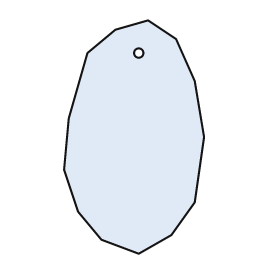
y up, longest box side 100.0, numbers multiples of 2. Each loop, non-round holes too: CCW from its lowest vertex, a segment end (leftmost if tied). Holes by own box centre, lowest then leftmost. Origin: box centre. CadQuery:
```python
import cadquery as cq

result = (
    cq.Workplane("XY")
    .moveTo(2.0, -50.0)
    .lineTo(16.0, -42.0)
    .lineTo(26.0, -28.0)
    .lineTo(30.0, 0.0)
    .lineTo(26.0, 24.0)
    .lineTo(18.0, 42.0)
    .lineTo(6.0, 50.0)
    .lineTo(-8.0, 46.0)
    .lineTo(-20.0, 36.0)
    .lineTo(-28.0, 8.0)
    .lineTo(-30.0, -14.0)
    .lineTo(-24.0, -32.0)
    .lineTo(-14.0, -44.0)
    .close()
    .moveTo(2.0, 36.0)
    .circle(2.0)
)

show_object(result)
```